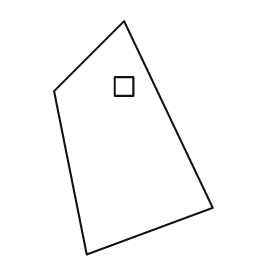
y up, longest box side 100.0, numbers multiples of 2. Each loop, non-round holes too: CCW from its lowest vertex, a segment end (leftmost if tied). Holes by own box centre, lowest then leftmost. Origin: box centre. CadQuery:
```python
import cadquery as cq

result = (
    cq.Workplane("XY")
    .moveTo(-20.0, -50.0)
    .lineTo(34.0, -30.0)
    .lineTo(-4.0, 50.0)
    .lineTo(-34.0, 20.0)
    .close()
    .moveTo(-8.0, 18.0)
    .lineTo(0.0, 18.0)
    .lineTo(0.0, 26.0)
    .lineTo(-8.0, 26.0)
    .close()
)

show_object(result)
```